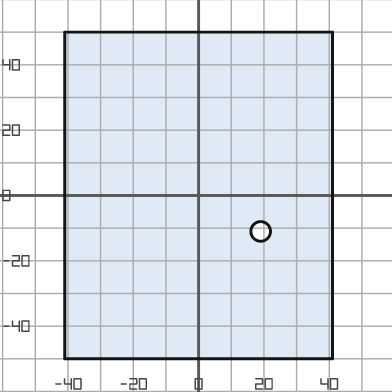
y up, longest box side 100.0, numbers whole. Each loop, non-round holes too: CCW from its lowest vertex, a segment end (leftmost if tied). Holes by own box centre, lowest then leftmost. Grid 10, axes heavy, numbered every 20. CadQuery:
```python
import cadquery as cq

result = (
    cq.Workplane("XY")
    .moveTo(-41.0, -50.0)
    .lineTo(41.0, -50.0)
    .lineTo(41.0, 50.0)
    .lineTo(-41.0, 50.0)
    .close()
    .moveTo(19.0, -11.0)
    .circle(3.0)
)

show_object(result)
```